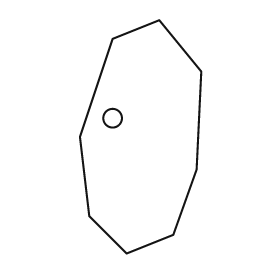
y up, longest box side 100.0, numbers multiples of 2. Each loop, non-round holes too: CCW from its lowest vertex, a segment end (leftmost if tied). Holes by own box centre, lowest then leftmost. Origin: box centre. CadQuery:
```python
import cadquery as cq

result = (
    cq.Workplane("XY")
    .moveTo(-6.0, -50.0)
    .lineTo(14.0, -42.0)
    .lineTo(24.0, -14.0)
    .lineTo(26.0, 28.0)
    .lineTo(8.0, 50.0)
    .lineTo(-12.0, 42.0)
    .lineTo(-26.0, 0.0)
    .lineTo(-22.0, -34.0)
    .close()
    .moveTo(-12.0, 8.0)
    .circle(4.0)
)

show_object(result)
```